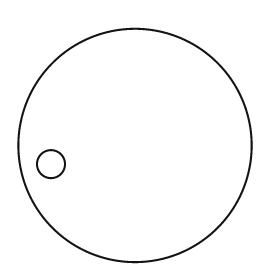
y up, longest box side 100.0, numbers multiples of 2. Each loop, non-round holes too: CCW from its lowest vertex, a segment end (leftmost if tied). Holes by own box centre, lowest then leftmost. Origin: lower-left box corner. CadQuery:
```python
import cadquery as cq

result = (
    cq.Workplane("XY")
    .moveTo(50.0, 50.0)
    .circle(50.0)
    .moveTo(14.0, 42.0)
    .circle(6.0)
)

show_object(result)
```